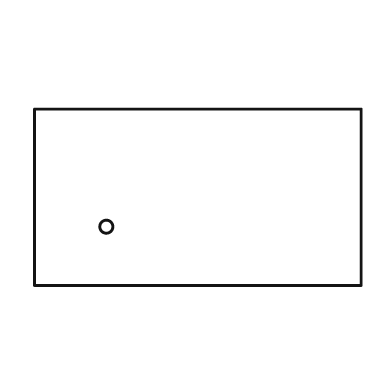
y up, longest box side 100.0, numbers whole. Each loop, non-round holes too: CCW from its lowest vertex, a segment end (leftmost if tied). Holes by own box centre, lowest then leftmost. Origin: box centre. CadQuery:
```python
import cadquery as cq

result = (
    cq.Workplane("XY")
    .moveTo(-50.0, -27.0)
    .lineTo(50.0, -27.0)
    .lineTo(50.0, 27.0)
    .lineTo(-50.0, 27.0)
    .close()
    .moveTo(-28.0, -9.0)
    .circle(2.0)
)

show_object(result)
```